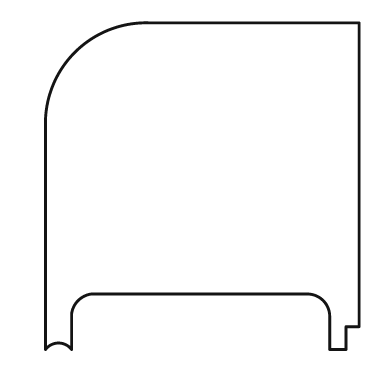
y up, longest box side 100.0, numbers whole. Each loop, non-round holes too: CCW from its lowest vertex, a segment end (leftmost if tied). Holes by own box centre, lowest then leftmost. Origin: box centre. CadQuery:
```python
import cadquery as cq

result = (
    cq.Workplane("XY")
    .moveTo(-48.0, -50.0)
    .threePointArc((-44.0, -48.0), (-40.0, -50.0))
    .lineTo(-40.0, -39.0)
    .threePointArc((-38.0, -35.0), (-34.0, -33.0))
    .lineTo(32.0, -33.0)
    .threePointArc((37.0, -35.0), (39.0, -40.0))
    .lineTo(39.0, -50.0)
    .lineTo(44.0, -50.0)
    .lineTo(44.0, -43.0)
    .lineTo(48.0, -43.0)
    .lineTo(48.0, 50.0)
    .lineTo(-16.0, 50.0)
    .threePointArc((-39.0, 41.0), (-48.0, 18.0))
    .close()
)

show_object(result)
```